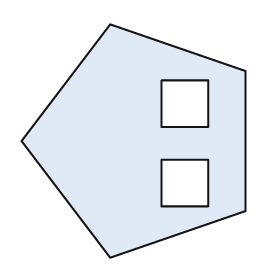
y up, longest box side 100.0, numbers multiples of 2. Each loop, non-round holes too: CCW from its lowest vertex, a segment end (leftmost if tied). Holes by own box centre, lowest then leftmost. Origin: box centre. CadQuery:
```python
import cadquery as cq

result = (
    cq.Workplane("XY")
    .moveTo(-10.0, -50.0)
    .lineTo(48.0, -30.0)
    .lineTo(48.0, 30.0)
    .lineTo(-10.0, 50.0)
    .lineTo(-48.0, 0.0)
    .close()
    .moveTo(12.0, -28.0)
    .lineTo(32.0, -28.0)
    .lineTo(32.0, -8.0)
    .lineTo(12.0, -8.0)
    .close()
    .moveTo(12.0, 6.0)
    .lineTo(32.0, 6.0)
    .lineTo(32.0, 26.0)
    .lineTo(12.0, 26.0)
    .close()
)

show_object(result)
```